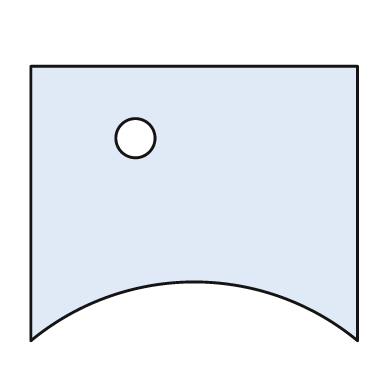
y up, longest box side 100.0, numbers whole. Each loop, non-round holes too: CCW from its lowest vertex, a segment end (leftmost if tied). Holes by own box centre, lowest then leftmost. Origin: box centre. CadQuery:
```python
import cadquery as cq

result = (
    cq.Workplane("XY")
    .moveTo(-50.0, -42.0)
    .threePointArc((0.0, -24.0), (50.0, -42.0))
    .lineTo(50.0, 42.0)
    .lineTo(-50.0, 42.0)
    .close()
    .moveTo(-18.0, 20.0)
    .circle(6.0)
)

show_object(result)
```